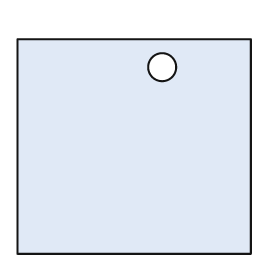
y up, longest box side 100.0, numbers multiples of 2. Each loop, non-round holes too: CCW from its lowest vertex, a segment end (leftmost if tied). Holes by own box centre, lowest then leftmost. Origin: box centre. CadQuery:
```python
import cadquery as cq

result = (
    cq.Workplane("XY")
    .moveTo(-50.0, -46.0)
    .lineTo(50.0, -46.0)
    .lineTo(50.0, 46.0)
    .lineTo(-50.0, 46.0)
    .close()
    .moveTo(12.0, 34.0)
    .circle(6.0)
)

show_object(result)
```